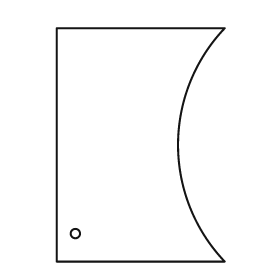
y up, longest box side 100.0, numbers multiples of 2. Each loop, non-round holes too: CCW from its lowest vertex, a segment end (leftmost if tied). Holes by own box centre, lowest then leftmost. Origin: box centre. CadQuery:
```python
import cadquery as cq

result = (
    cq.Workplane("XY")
    .moveTo(-36.0, -50.0)
    .lineTo(36.0, -50.0)
    .threePointArc((16.0, 0.0), (36.0, 50.0))
    .lineTo(-36.0, 50.0)
    .close()
    .moveTo(-28.0, -38.0)
    .circle(2.0)
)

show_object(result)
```